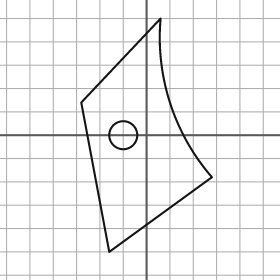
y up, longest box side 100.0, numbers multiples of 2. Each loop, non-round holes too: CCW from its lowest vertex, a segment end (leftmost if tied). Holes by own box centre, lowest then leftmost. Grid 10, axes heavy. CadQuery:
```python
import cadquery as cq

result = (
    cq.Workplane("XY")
    .moveTo(-16.0, -50.0)
    .lineTo(28.0, -18.0)
    .threePointArc((10.0, 14.0), (6.0, 50.0))
    .lineTo(-28.0, 14.0)
    .close()
    .moveTo(-10.0, 0.0)
    .circle(6.0)
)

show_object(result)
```